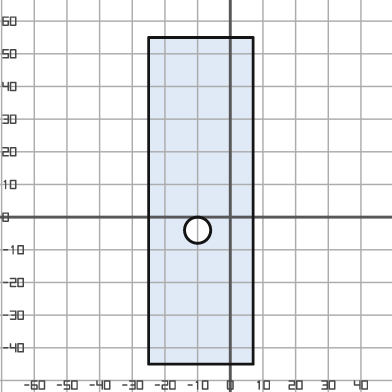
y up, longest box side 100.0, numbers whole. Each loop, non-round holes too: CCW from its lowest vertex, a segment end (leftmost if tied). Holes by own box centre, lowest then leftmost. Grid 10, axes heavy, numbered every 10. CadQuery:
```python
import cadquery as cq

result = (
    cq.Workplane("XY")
    .moveTo(-25.0, -45.0)
    .lineTo(7.0, -45.0)
    .lineTo(7.0, 55.0)
    .lineTo(-25.0, 55.0)
    .close()
    .moveTo(-10.0, -4.0)
    .circle(4.0)
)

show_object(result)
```